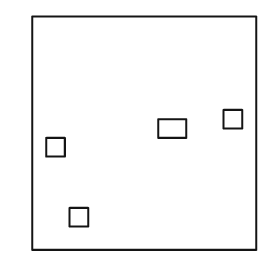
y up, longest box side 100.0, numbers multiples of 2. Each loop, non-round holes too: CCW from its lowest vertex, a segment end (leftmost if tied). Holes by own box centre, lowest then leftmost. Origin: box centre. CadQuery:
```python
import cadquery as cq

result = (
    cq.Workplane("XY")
    .moveTo(-48.0, -50.0)
    .lineTo(48.0, -50.0)
    .lineTo(48.0, 50.0)
    .lineTo(-48.0, 50.0)
    .close()
    .moveTo(-32.0, -40.0)
    .lineTo(-24.0, -40.0)
    .lineTo(-24.0, -32.0)
    .lineTo(-32.0, -32.0)
    .close()
    .moveTo(-42.0, -10.0)
    .lineTo(-34.0, -10.0)
    .lineTo(-34.0, -2.0)
    .lineTo(-42.0, -2.0)
    .close()
    .moveTo(6.0, -2.0)
    .lineTo(18.0, -2.0)
    .lineTo(18.0, 6.0)
    .lineTo(6.0, 6.0)
    .close()
    .moveTo(34.0, 2.0)
    .lineTo(42.0, 2.0)
    .lineTo(42.0, 10.0)
    .lineTo(34.0, 10.0)
    .close()
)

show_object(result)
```